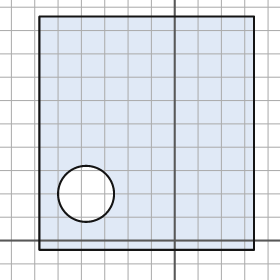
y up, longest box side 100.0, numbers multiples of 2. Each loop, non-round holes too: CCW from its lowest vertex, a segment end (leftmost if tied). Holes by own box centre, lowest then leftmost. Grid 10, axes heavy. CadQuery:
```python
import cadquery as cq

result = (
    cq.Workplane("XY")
    .moveTo(-58.0, -4.0)
    .lineTo(34.0, -4.0)
    .lineTo(34.0, 96.0)
    .lineTo(-58.0, 96.0)
    .close()
    .moveTo(-38.0, 20.0)
    .circle(12.0)
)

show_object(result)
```